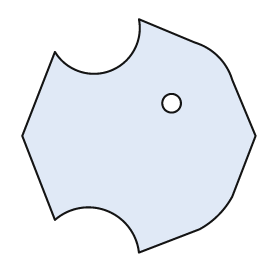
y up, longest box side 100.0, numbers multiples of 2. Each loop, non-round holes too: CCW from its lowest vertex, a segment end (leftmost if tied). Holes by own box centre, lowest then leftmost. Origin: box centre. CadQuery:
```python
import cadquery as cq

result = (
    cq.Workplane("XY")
    .moveTo(0.0, -50.0)
    .lineTo(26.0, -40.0)
    .threePointArc((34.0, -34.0), (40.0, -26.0))
    .lineTo(50.0, 0.0)
    .lineTo(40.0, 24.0)
    .threePointArc((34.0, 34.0), (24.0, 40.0))
    .lineTo(0.0, 50.0)
    .threePointArc((-12.0, 28.0), (-36.0, 36.0))
    .lineTo(-50.0, 0.0)
    .lineTo(-36.0, -36.0)
    .threePointArc((-14.0, -32.0), (0.0, -50.0))
    .close()
    .moveTo(14.0, 14.0)
    .circle(4.0)
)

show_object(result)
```